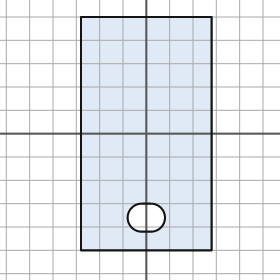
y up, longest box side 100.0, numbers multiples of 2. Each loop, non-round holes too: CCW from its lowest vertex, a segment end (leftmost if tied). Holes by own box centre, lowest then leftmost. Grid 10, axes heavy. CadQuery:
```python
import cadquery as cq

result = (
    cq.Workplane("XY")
    .moveTo(-28.0, -50.0)
    .lineTo(28.0, -50.0)
    .lineTo(28.0, 50.0)
    .lineTo(-28.0, 50.0)
    .close()
    .moveTo(-2.0, -42.0)
    .lineTo(2.0, -42.0)
    .threePointArc((8.0, -36.0), (2.0, -30.0))
    .lineTo(-2.0, -30.0)
    .threePointArc((-8.0, -36.0), (-2.0, -42.0))
    .close()
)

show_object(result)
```